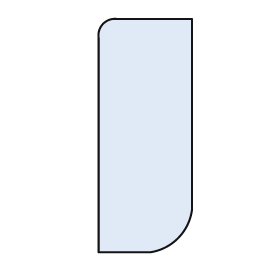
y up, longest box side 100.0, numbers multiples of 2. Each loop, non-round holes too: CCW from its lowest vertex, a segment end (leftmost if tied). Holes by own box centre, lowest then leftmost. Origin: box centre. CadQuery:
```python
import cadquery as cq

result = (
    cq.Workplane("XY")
    .moveTo(-20.0, -50.0)
    .lineTo(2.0, -50.0)
    .threePointArc((14.0, -44.0), (20.0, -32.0))
    .lineTo(20.0, 50.0)
    .lineTo(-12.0, 50.0)
    .threePointArc((-18.0, 48.0), (-20.0, 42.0))
    .close()
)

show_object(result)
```